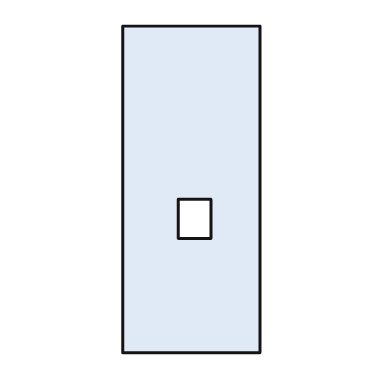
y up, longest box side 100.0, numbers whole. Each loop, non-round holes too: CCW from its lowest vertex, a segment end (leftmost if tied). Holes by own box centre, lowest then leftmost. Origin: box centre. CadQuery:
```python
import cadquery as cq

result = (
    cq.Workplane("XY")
    .moveTo(-21.0, -50.0)
    .lineTo(21.0, -50.0)
    .lineTo(21.0, 50.0)
    .lineTo(-21.0, 50.0)
    .close()
    .moveTo(-4.0, -15.0)
    .lineTo(6.0, -15.0)
    .lineTo(6.0, -3.0)
    .lineTo(-4.0, -3.0)
    .close()
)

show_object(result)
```